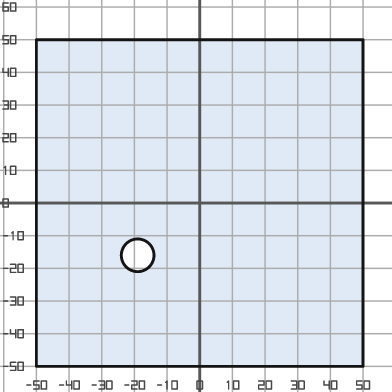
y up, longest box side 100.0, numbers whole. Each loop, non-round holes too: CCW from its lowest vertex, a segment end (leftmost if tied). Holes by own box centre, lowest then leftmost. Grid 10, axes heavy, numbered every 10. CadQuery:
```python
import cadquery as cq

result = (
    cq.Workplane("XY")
    .moveTo(-50.0, -50.0)
    .lineTo(50.0, -50.0)
    .lineTo(50.0, 50.0)
    .lineTo(-50.0, 50.0)
    .close()
    .moveTo(-19.0, -16.0)
    .circle(5.0)
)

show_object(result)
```